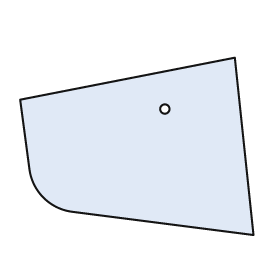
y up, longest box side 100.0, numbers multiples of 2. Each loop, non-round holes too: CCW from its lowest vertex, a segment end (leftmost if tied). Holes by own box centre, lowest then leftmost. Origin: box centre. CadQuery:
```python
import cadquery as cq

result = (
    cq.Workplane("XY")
    .moveTo(50.0, -38.0)
    .lineTo(42.0, 38.0)
    .lineTo(-50.0, 20.0)
    .lineTo(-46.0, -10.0)
    .threePointArc((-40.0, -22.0), (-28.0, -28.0))
    .close()
    .moveTo(12.0, 16.0)
    .circle(2.0)
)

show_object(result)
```